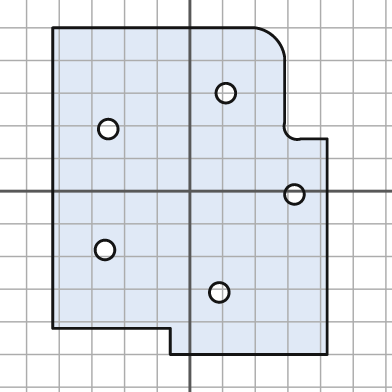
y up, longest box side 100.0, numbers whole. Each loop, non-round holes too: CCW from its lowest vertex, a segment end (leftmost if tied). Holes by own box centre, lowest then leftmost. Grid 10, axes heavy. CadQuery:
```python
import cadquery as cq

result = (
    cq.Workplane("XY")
    .moveTo(-6.0, -50.0)
    .lineTo(42.0, -50.0)
    .lineTo(42.0, 16.0)
    .lineTo(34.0, 16.0)
    .threePointArc((30.0, 17.0), (29.0, 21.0))
    .lineTo(29.0, 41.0)
    .threePointArc((26.0, 47.0), (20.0, 50.0))
    .lineTo(-42.0, 50.0)
    .lineTo(-42.0, -42.0)
    .lineTo(-6.0, -42.0)
    .close()
    .moveTo(9.0, -31.0)
    .circle(3.0)
    .moveTo(-26.0, -18.0)
    .circle(3.0)
    .moveTo(32.0, -1.0)
    .circle(3.0)
    .moveTo(-25.0, 19.0)
    .circle(3.0)
    .moveTo(11.0, 30.0)
    .circle(3.0)
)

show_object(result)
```